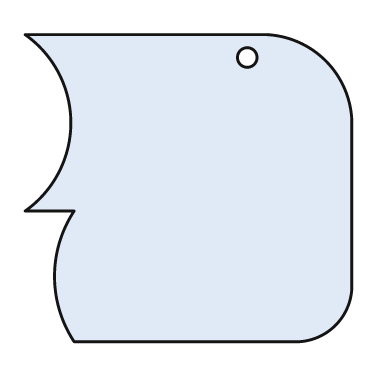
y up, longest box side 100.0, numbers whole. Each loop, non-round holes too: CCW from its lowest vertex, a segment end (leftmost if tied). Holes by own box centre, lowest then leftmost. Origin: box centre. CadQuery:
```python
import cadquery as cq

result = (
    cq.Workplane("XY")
    .moveTo(-35.0, -47.0)
    .lineTo(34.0, -47.0)
    .threePointArc((45.0, -42.0), (50.0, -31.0))
    .lineTo(50.0, 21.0)
    .threePointArc((42.0, 39.0), (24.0, 47.0))
    .lineTo(-50.0, 47.0)
    .threePointArc((-36.0, 20.0), (-50.0, -7.0))
    .lineTo(-35.0, -7.0)
    .threePointArc((-41.0, -27.0), (-35.0, -47.0))
    .close()
    .moveTo(18.0, 40.0)
    .circle(3.0)
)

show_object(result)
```